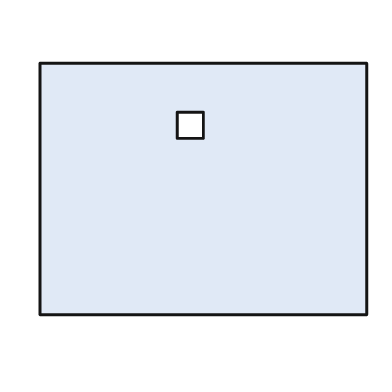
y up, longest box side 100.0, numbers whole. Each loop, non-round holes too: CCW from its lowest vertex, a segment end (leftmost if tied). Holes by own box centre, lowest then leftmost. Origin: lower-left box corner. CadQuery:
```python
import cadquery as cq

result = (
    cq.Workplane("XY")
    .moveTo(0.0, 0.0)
    .lineTo(100.0, 0.0)
    .lineTo(100.0, 77.0)
    .lineTo(0.0, 77.0)
    .close()
    .moveTo(42.0, 54.0)
    .lineTo(50.0, 54.0)
    .lineTo(50.0, 62.0)
    .lineTo(42.0, 62.0)
    .close()
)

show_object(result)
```